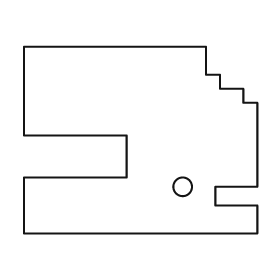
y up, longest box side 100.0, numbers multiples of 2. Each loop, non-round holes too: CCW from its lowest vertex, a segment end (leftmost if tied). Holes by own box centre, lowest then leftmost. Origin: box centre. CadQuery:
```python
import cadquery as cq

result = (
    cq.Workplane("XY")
    .moveTo(-50.0, -40.0)
    .lineTo(50.0, -40.0)
    .lineTo(50.0, -28.0)
    .lineTo(32.0, -28.0)
    .lineTo(32.0, -20.0)
    .lineTo(50.0, -20.0)
    .lineTo(50.0, 16.0)
    .lineTo(44.0, 16.0)
    .lineTo(44.0, 22.0)
    .lineTo(34.0, 22.0)
    .lineTo(34.0, 28.0)
    .lineTo(28.0, 28.0)
    .lineTo(28.0, 40.0)
    .lineTo(-50.0, 40.0)
    .lineTo(-50.0, 2.0)
    .lineTo(-6.0, 2.0)
    .lineTo(-6.0, -16.0)
    .lineTo(-50.0, -16.0)
    .close()
    .moveTo(18.0, -20.0)
    .circle(4.0)
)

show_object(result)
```